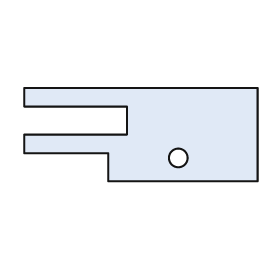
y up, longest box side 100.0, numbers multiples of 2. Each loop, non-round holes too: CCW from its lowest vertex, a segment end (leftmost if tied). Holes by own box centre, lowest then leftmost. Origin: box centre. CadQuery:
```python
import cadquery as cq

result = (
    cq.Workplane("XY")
    .moveTo(-14.0, -20.0)
    .lineTo(50.0, -20.0)
    .lineTo(50.0, 20.0)
    .lineTo(-50.0, 20.0)
    .lineTo(-50.0, 12.0)
    .lineTo(-6.0, 12.0)
    .lineTo(-6.0, 0.0)
    .lineTo(-50.0, 0.0)
    .lineTo(-50.0, -8.0)
    .lineTo(-14.0, -8.0)
    .close()
    .moveTo(16.0, -10.0)
    .circle(4.0)
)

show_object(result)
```